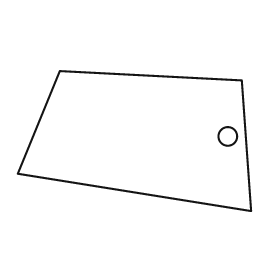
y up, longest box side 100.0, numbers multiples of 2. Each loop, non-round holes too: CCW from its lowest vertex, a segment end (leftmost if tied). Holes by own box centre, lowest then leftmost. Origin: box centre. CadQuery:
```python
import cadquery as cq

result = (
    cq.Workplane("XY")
    .moveTo(50.0, -30.0)
    .lineTo(46.0, 26.0)
    .lineTo(-32.0, 30.0)
    .lineTo(-50.0, -14.0)
    .close()
    .moveTo(40.0, 2.0)
    .circle(4.0)
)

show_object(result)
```